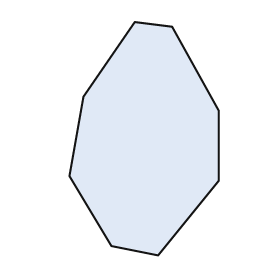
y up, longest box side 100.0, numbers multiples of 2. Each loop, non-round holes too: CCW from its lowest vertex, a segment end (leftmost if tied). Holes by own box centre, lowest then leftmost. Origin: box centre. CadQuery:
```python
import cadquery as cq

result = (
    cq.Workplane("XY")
    .moveTo(6.0, -50.0)
    .lineTo(32.0, -18.0)
    .lineTo(32.0, 12.0)
    .lineTo(12.0, 48.0)
    .lineTo(-4.0, 50.0)
    .lineTo(-26.0, 18.0)
    .lineTo(-32.0, -16.0)
    .lineTo(-14.0, -46.0)
    .close()
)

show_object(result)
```